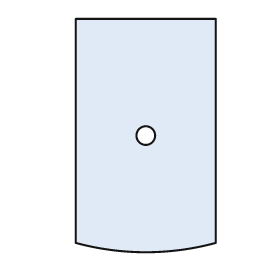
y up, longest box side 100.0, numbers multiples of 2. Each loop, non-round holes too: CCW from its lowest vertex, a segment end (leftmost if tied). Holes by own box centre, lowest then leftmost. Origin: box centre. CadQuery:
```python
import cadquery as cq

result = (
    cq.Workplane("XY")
    .moveTo(-30.0, -46.0)
    .threePointArc((0.0, -50.0), (30.0, -46.0))
    .lineTo(30.0, 50.0)
    .lineTo(-30.0, 50.0)
    .close()
    .moveTo(0.0, 0.0)
    .circle(4.0)
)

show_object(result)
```